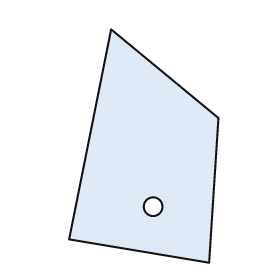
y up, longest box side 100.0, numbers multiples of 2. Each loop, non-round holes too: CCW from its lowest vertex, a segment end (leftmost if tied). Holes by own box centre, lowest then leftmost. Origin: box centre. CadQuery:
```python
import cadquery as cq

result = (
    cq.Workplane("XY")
    .moveTo(28.0, -50.0)
    .lineTo(32.0, 12.0)
    .lineTo(-14.0, 50.0)
    .lineTo(-32.0, -40.0)
    .close()
    .moveTo(4.0, -26.0)
    .circle(4.0)
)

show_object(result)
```